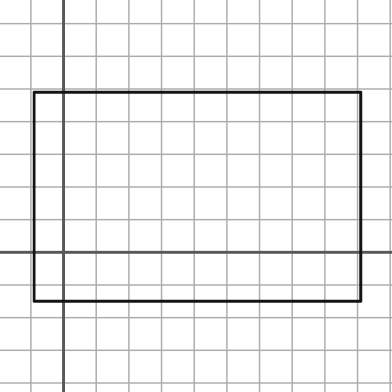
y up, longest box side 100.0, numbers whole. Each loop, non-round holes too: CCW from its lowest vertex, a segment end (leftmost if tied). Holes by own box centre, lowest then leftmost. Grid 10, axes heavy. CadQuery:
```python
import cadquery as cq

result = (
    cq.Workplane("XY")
    .moveTo(-9.0, -15.0)
    .lineTo(91.0, -15.0)
    .lineTo(91.0, 49.0)
    .lineTo(-9.0, 49.0)
    .close()
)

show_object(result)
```